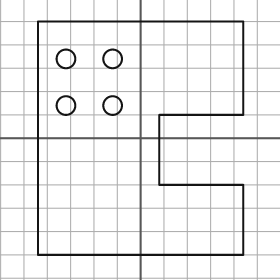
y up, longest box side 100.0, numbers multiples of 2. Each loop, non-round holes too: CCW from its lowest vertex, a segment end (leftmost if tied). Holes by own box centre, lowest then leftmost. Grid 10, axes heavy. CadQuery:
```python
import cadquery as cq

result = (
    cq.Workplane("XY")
    .moveTo(-44.0, -50.0)
    .lineTo(44.0, -50.0)
    .lineTo(44.0, -20.0)
    .lineTo(8.0, -20.0)
    .lineTo(8.0, 10.0)
    .lineTo(44.0, 10.0)
    .lineTo(44.0, 50.0)
    .lineTo(-44.0, 50.0)
    .close()
    .moveTo(-32.0, 14.0)
    .circle(4.0)
    .moveTo(-12.0, 14.0)
    .circle(4.0)
    .moveTo(-32.0, 34.0)
    .circle(4.0)
    .moveTo(-12.0, 34.0)
    .circle(4.0)
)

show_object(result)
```